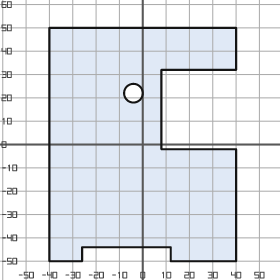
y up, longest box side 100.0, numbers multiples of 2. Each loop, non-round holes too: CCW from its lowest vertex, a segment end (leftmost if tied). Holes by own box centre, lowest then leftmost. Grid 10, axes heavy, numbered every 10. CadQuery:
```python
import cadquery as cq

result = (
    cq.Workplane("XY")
    .moveTo(-40.0, -50.0)
    .lineTo(-26.0, -50.0)
    .lineTo(-26.0, -44.0)
    .lineTo(12.0, -44.0)
    .lineTo(12.0, -50.0)
    .lineTo(40.0, -50.0)
    .lineTo(40.0, -2.0)
    .lineTo(8.0, -2.0)
    .lineTo(8.0, 32.0)
    .lineTo(40.0, 32.0)
    .lineTo(40.0, 50.0)
    .lineTo(-40.0, 50.0)
    .close()
    .moveTo(-4.0, 22.0)
    .circle(4.0)
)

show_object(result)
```